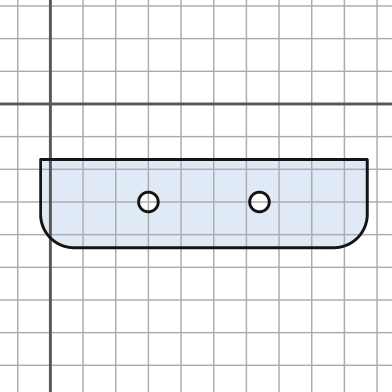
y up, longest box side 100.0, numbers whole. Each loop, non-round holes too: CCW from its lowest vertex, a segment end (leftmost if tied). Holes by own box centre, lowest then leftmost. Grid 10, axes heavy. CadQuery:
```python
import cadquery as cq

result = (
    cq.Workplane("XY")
    .moveTo(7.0, -44.0)
    .lineTo(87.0, -44.0)
    .threePointArc((94.0, -41.0), (97.0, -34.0))
    .lineTo(97.0, -17.0)
    .lineTo(-3.0, -17.0)
    .lineTo(-3.0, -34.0)
    .threePointArc((0.0, -41.0), (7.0, -44.0))
    .close()
    .moveTo(30.0, -30.0)
    .circle(3.0)
    .moveTo(64.0, -30.0)
    .circle(3.0)
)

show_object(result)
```